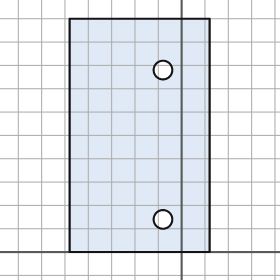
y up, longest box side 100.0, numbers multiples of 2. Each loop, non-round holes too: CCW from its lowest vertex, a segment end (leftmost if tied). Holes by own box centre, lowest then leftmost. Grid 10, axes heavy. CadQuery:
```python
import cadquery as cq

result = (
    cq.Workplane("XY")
    .moveTo(-48.0, 0.0)
    .lineTo(12.0, 0.0)
    .lineTo(12.0, 100.0)
    .lineTo(-48.0, 100.0)
    .close()
    .moveTo(-8.0, 14.0)
    .circle(4.0)
    .moveTo(-8.0, 78.0)
    .circle(4.0)
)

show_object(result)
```